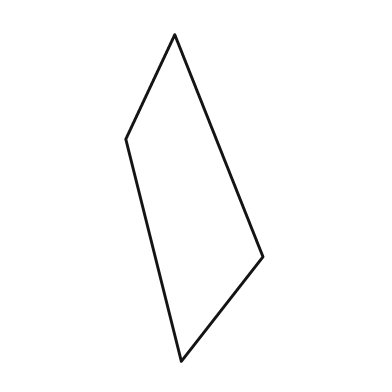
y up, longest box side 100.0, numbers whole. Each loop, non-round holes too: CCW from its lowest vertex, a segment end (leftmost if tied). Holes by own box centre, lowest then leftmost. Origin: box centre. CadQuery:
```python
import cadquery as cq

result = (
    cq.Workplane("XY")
    .moveTo(-4.0, -50.0)
    .lineTo(21.0, -18.0)
    .lineTo(-6.0, 50.0)
    .lineTo(-21.0, 18.0)
    .close()
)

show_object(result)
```